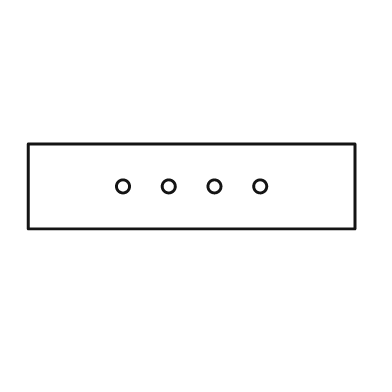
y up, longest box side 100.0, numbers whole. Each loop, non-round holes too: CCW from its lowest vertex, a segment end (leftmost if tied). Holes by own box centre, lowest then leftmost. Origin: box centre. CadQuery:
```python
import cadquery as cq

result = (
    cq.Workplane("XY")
    .moveTo(-50.0, -13.0)
    .lineTo(50.0, -13.0)
    .lineTo(50.0, 13.0)
    .lineTo(-50.0, 13.0)
    .close()
    .moveTo(-21.0, 0.0)
    .circle(2.0)
    .moveTo(-7.0, 0.0)
    .circle(2.0)
    .moveTo(7.0, 0.0)
    .circle(2.0)
    .moveTo(21.0, 0.0)
    .circle(2.0)
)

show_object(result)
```